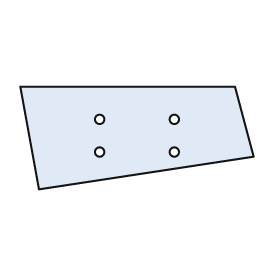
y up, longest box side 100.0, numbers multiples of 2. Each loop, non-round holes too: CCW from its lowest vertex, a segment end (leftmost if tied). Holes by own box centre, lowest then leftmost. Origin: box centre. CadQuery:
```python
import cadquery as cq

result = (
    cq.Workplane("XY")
    .moveTo(-42.0, -22.0)
    .lineTo(50.0, -8.0)
    .lineTo(42.0, 22.0)
    .lineTo(-50.0, 22.0)
    .close()
    .moveTo(-16.0, -6.0)
    .circle(2.0)
    .moveTo(16.0, -6.0)
    .circle(2.0)
    .moveTo(-16.0, 8.0)
    .circle(2.0)
    .moveTo(16.0, 8.0)
    .circle(2.0)
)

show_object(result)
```